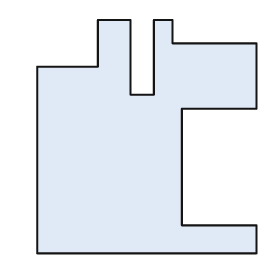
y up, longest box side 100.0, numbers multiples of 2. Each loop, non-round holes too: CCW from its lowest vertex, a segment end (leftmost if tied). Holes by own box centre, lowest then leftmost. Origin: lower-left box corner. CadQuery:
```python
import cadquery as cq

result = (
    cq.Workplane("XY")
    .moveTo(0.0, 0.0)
    .lineTo(94.0, 0.0)
    .lineTo(94.0, 12.0)
    .lineTo(62.0, 12.0)
    .lineTo(62.0, 62.0)
    .lineTo(94.0, 62.0)
    .lineTo(94.0, 90.0)
    .lineTo(58.0, 90.0)
    .lineTo(58.0, 100.0)
    .lineTo(50.0, 100.0)
    .lineTo(50.0, 68.0)
    .lineTo(40.0, 68.0)
    .lineTo(40.0, 100.0)
    .lineTo(26.0, 100.0)
    .lineTo(26.0, 80.0)
    .lineTo(0.0, 80.0)
    .close()
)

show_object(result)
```